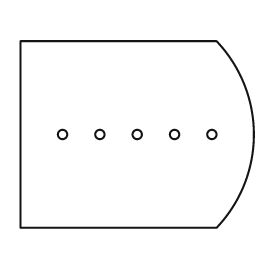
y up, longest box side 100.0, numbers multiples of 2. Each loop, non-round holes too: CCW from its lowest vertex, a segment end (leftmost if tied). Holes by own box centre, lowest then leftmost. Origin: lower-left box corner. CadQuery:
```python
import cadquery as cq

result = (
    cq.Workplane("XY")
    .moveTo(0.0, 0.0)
    .lineTo(84.0, 0.0)
    .threePointArc((100.0, 40.0), (84.0, 80.0))
    .lineTo(0.0, 80.0)
    .close()
    .moveTo(18.0, 40.0)
    .circle(2.0)
    .moveTo(34.0, 40.0)
    .circle(2.0)
    .moveTo(50.0, 40.0)
    .circle(2.0)
    .moveTo(66.0, 40.0)
    .circle(2.0)
    .moveTo(82.0, 40.0)
    .circle(2.0)
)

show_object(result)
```